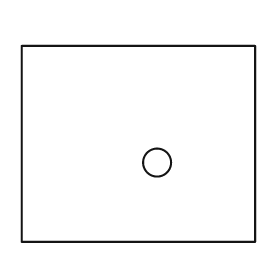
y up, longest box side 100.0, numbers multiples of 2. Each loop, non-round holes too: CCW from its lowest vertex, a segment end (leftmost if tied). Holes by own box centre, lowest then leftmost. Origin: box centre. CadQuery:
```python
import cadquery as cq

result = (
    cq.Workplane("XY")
    .moveTo(-50.0, -42.0)
    .lineTo(50.0, -42.0)
    .lineTo(50.0, 42.0)
    .lineTo(-50.0, 42.0)
    .close()
    .moveTo(8.0, -8.0)
    .circle(6.0)
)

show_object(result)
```